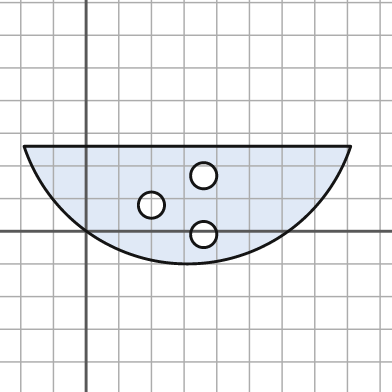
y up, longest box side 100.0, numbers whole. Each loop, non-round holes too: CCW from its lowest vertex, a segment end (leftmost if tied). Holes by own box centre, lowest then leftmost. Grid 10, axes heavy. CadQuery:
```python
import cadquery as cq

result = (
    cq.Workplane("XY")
    .moveTo(-19.0, 26.0)
    .threePointArc((31.0, -10.0), (81.0, 26.0))
    .close()
    .moveTo(36.0, -1.0)
    .circle(4.0)
    .moveTo(20.0, 8.0)
    .circle(4.0)
    .moveTo(36.0, 17.0)
    .circle(4.0)
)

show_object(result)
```